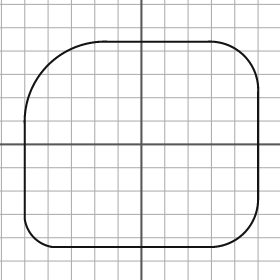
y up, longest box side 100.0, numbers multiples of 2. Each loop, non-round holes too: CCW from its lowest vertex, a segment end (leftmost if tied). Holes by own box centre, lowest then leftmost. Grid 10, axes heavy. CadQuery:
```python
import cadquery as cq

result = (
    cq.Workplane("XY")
    .moveTo(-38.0, -44.0)
    .lineTo(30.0, -44.0)
    .threePointArc((44.0, -38.0), (50.0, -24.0))
    .lineTo(50.0, 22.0)
    .threePointArc((44.0, 38.0), (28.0, 44.0))
    .lineTo(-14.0, 44.0)
    .threePointArc((-40.0, 34.0), (-50.0, 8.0))
    .lineTo(-50.0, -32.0)
    .threePointArc((-46.0, -40.0), (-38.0, -44.0))
    .close()
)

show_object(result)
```